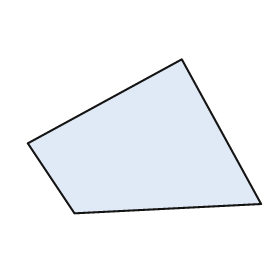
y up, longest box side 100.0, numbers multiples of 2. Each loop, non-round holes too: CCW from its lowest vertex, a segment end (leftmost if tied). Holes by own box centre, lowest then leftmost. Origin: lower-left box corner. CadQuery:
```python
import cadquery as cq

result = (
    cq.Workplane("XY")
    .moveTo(20.0, 0.0)
    .lineTo(100.0, 4.0)
    .lineTo(66.0, 66.0)
    .lineTo(0.0, 30.0)
    .close()
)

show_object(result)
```